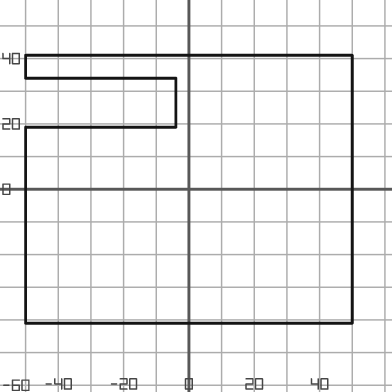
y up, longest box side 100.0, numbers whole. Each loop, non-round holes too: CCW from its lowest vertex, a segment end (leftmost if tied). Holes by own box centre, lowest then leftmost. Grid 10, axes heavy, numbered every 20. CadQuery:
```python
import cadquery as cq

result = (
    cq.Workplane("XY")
    .moveTo(-50.0, -41.0)
    .lineTo(50.0, -41.0)
    .lineTo(50.0, 41.0)
    .lineTo(-50.0, 41.0)
    .lineTo(-50.0, 34.0)
    .lineTo(-4.0, 34.0)
    .lineTo(-4.0, 19.0)
    .lineTo(-50.0, 19.0)
    .close()
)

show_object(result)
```